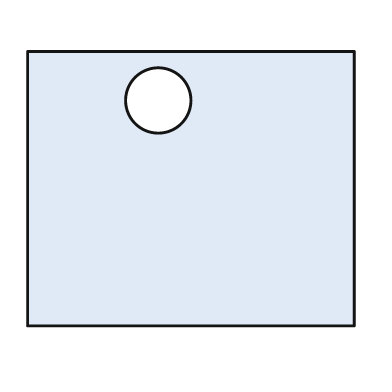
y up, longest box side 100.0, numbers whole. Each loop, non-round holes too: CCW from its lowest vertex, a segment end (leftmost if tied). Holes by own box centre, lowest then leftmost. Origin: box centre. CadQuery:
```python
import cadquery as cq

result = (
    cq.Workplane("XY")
    .moveTo(-50.0, -42.0)
    .lineTo(50.0, -42.0)
    .lineTo(50.0, 42.0)
    .lineTo(-50.0, 42.0)
    .close()
    .moveTo(-10.0, 27.0)
    .circle(10.0)
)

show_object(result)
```